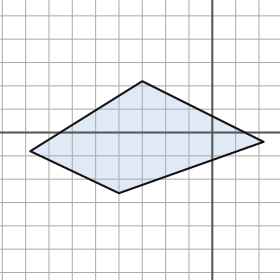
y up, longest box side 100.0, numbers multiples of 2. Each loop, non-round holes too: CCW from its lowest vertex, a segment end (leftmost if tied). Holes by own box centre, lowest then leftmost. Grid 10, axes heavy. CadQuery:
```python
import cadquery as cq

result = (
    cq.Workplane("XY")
    .moveTo(-40.0, -26.0)
    .lineTo(22.0, -4.0)
    .lineTo(-30.0, 22.0)
    .lineTo(-78.0, -8.0)
    .close()
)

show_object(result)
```